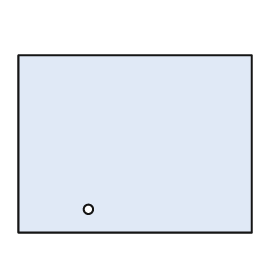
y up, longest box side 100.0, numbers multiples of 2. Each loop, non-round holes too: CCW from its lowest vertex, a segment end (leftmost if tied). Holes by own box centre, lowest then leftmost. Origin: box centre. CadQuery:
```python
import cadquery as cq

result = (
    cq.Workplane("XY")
    .moveTo(-50.0, -38.0)
    .lineTo(50.0, -38.0)
    .lineTo(50.0, 38.0)
    .lineTo(-50.0, 38.0)
    .close()
    .moveTo(-20.0, -28.0)
    .circle(2.0)
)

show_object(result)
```